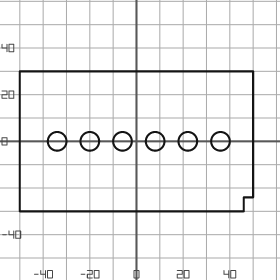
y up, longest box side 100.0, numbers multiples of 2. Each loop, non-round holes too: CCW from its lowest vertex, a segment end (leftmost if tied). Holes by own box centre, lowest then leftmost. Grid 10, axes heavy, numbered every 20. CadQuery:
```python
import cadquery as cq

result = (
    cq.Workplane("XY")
    .moveTo(-50.0, -30.0)
    .lineTo(46.0, -30.0)
    .lineTo(46.0, -24.0)
    .lineTo(50.0, -24.0)
    .lineTo(50.0, 30.0)
    .lineTo(-50.0, 30.0)
    .close()
    .moveTo(-34.0, 0.0)
    .circle(4.0)
    .moveTo(-20.0, 0.0)
    .circle(4.0)
    .moveTo(-6.0, 0.0)
    .circle(4.0)
    .moveTo(8.0, 0.0)
    .circle(4.0)
    .moveTo(22.0, 0.0)
    .circle(4.0)
    .moveTo(36.0, 0.0)
    .circle(4.0)
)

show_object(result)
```